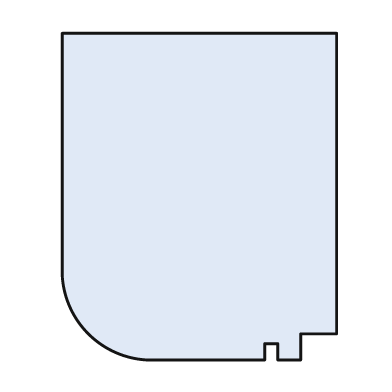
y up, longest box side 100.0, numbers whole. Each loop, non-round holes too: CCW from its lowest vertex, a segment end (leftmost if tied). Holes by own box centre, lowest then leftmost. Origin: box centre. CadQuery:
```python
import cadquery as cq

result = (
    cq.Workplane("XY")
    .moveTo(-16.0, -50.0)
    .lineTo(20.0, -50.0)
    .lineTo(20.0, -45.0)
    .lineTo(24.0, -45.0)
    .lineTo(24.0, -50.0)
    .lineTo(31.0, -50.0)
    .lineTo(31.0, -42.0)
    .lineTo(42.0, -42.0)
    .lineTo(42.0, 50.0)
    .lineTo(-42.0, 50.0)
    .lineTo(-42.0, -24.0)
    .threePointArc((-34.0, -42.0), (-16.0, -50.0))
    .close()
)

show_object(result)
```